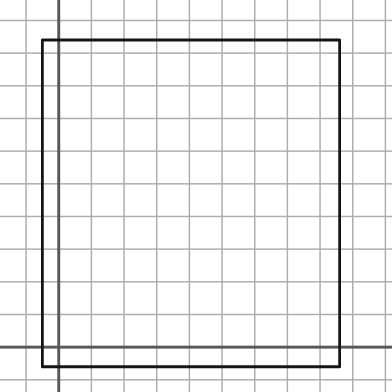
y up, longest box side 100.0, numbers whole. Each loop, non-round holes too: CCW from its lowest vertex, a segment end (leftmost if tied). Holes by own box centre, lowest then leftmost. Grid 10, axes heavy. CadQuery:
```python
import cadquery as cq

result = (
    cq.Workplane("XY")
    .moveTo(-5.0, -6.0)
    .lineTo(86.0, -6.0)
    .lineTo(86.0, 94.0)
    .lineTo(-5.0, 94.0)
    .close()
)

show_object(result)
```